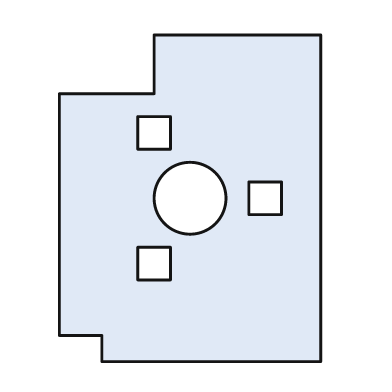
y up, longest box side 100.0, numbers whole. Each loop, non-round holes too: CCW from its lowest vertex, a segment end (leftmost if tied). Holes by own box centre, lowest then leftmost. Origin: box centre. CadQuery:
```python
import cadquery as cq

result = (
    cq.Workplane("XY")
    .moveTo(-27.0, -50.0)
    .lineTo(40.0, -50.0)
    .lineTo(40.0, 50.0)
    .lineTo(-11.0, 50.0)
    .lineTo(-11.0, 32.0)
    .lineTo(-40.0, 32.0)
    .lineTo(-40.0, -42.0)
    .lineTo(-27.0, -42.0)
    .close()
    .moveTo(-16.0, -25.0)
    .lineTo(-6.0, -25.0)
    .lineTo(-6.0, -15.0)
    .lineTo(-16.0, -15.0)
    .close()
    .moveTo(0.0, 0.0)
    .circle(11.0)
    .moveTo(18.0, -5.0)
    .lineTo(28.0, -5.0)
    .lineTo(28.0, 5.0)
    .lineTo(18.0, 5.0)
    .close()
    .moveTo(-16.0, 15.0)
    .lineTo(-6.0, 15.0)
    .lineTo(-6.0, 25.0)
    .lineTo(-16.0, 25.0)
    .close()
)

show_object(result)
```